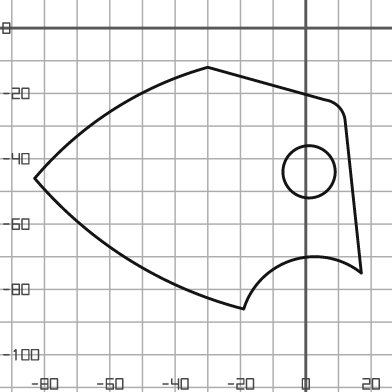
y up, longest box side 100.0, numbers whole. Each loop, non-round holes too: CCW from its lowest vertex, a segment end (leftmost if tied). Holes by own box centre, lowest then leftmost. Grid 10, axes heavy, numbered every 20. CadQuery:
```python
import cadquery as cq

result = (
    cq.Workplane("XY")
    .moveTo(-19.0, -86.0)
    .threePointArc((-4.0, -71.0), (17.0, -75.0))
    .lineTo(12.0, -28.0)
    .threePointArc((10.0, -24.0), (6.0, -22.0))
    .lineTo(-30.0, -12.0)
    .threePointArc((-59.0, -25.0), (-83.0, -46.0))
    .threePointArc((-54.0, -71.0), (-19.0, -86.0))
    .close()
    .moveTo(1.0, -44.0)
    .circle(8.0)
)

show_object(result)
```